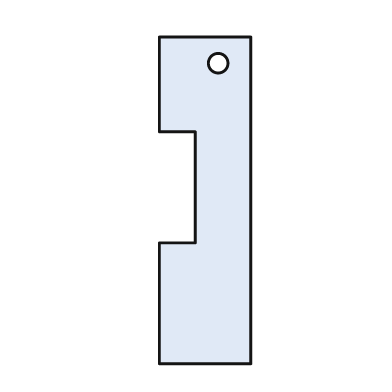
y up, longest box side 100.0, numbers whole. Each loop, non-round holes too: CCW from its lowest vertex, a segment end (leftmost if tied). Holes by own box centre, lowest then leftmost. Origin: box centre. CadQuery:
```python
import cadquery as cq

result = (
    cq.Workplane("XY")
    .moveTo(-14.0, -50.0)
    .lineTo(14.0, -50.0)
    .lineTo(14.0, 50.0)
    .lineTo(-14.0, 50.0)
    .lineTo(-14.0, 21.0)
    .lineTo(-3.0, 21.0)
    .lineTo(-3.0, -13.0)
    .lineTo(-14.0, -13.0)
    .close()
    .moveTo(4.0, 42.0)
    .circle(3.0)
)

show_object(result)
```